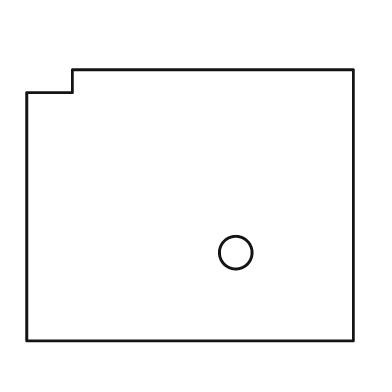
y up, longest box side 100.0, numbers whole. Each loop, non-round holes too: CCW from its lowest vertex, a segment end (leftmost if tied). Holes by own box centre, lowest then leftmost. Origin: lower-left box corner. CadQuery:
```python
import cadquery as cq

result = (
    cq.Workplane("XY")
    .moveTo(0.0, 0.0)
    .lineTo(100.0, 0.0)
    .lineTo(100.0, 83.0)
    .lineTo(14.0, 83.0)
    .lineTo(14.0, 76.0)
    .lineTo(0.0, 76.0)
    .close()
    .moveTo(64.0, 27.0)
    .circle(5.0)
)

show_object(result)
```